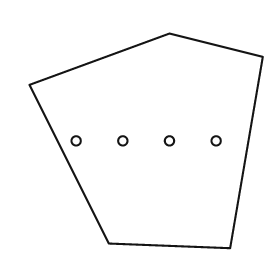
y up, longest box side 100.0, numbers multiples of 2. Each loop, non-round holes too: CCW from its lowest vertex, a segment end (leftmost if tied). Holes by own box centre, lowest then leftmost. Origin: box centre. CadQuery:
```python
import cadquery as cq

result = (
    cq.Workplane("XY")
    .moveTo(36.0, -46.0)
    .lineTo(50.0, 36.0)
    .lineTo(10.0, 46.0)
    .lineTo(-50.0, 24.0)
    .lineTo(-16.0, -44.0)
    .close()
    .moveTo(-30.0, 0.0)
    .circle(2.0)
    .moveTo(-10.0, 0.0)
    .circle(2.0)
    .moveTo(10.0, 0.0)
    .circle(2.0)
    .moveTo(30.0, 0.0)
    .circle(2.0)
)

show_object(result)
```